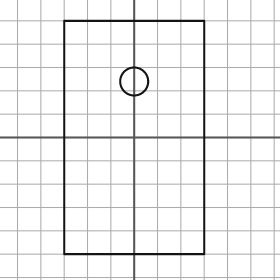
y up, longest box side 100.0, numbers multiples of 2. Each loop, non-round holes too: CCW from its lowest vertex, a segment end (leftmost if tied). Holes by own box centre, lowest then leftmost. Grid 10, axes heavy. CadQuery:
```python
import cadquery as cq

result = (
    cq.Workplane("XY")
    .moveTo(-30.0, -50.0)
    .lineTo(30.0, -50.0)
    .lineTo(30.0, 50.0)
    .lineTo(-30.0, 50.0)
    .close()
    .moveTo(0.0, 24.0)
    .circle(6.0)
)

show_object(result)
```